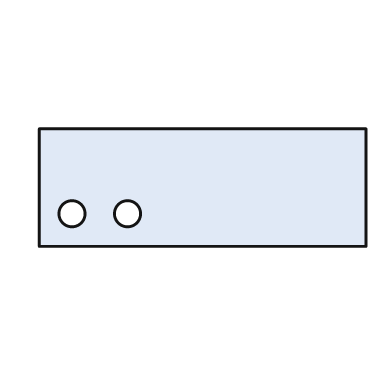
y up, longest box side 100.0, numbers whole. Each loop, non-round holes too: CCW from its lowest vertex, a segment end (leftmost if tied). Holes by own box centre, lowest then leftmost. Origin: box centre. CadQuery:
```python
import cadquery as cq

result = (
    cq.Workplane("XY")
    .moveTo(-50.0, -18.0)
    .lineTo(50.0, -18.0)
    .lineTo(50.0, 18.0)
    .lineTo(-50.0, 18.0)
    .close()
    .moveTo(-40.0, -8.0)
    .circle(4.0)
    .moveTo(-23.0, -8.0)
    .circle(4.0)
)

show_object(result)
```